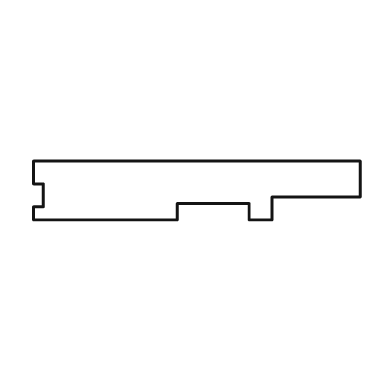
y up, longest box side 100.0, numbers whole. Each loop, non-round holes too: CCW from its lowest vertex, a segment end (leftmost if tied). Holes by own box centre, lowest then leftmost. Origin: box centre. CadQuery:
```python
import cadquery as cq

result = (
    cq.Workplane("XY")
    .moveTo(-50.0, -9.0)
    .lineTo(-6.0, -9.0)
    .lineTo(-6.0, -4.0)
    .lineTo(16.0, -4.0)
    .lineTo(16.0, -9.0)
    .lineTo(23.0, -9.0)
    .lineTo(23.0, -2.0)
    .lineTo(50.0, -2.0)
    .lineTo(50.0, 9.0)
    .lineTo(-50.0, 9.0)
    .lineTo(-50.0, 2.0)
    .lineTo(-47.0, 2.0)
    .lineTo(-47.0, -5.0)
    .lineTo(-50.0, -5.0)
    .close()
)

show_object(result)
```